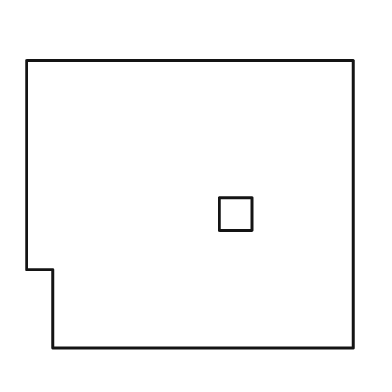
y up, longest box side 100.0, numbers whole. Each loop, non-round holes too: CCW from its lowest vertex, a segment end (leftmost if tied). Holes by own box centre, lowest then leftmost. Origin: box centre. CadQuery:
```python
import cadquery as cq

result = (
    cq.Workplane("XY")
    .moveTo(-42.0, -44.0)
    .lineTo(50.0, -44.0)
    .lineTo(50.0, 44.0)
    .lineTo(-50.0, 44.0)
    .lineTo(-50.0, -20.0)
    .lineTo(-42.0, -20.0)
    .close()
    .moveTo(9.0, -8.0)
    .lineTo(19.0, -8.0)
    .lineTo(19.0, 2.0)
    .lineTo(9.0, 2.0)
    .close()
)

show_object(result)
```